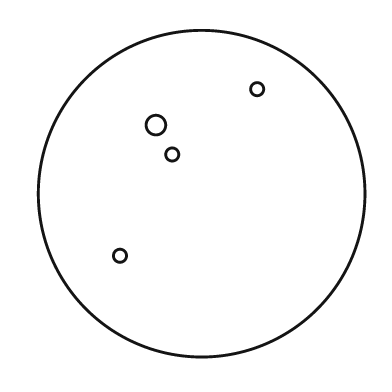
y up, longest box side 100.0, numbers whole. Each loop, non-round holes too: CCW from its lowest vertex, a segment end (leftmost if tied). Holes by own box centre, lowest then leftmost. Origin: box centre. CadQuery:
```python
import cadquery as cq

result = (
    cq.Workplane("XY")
    .moveTo(0.0, 0.0)
    .circle(50.0)
    .moveTo(-25.0, -19.0)
    .circle(2.0)
    .moveTo(-9.0, 12.0)
    .circle(2.0)
    .moveTo(-14.0, 21.0)
    .circle(3.0)
    .moveTo(17.0, 32.0)
    .circle(2.0)
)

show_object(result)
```